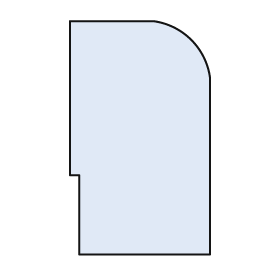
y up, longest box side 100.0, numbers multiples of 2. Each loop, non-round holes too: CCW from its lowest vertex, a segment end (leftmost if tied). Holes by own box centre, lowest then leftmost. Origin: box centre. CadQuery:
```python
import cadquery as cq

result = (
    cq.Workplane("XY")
    .moveTo(-26.0, -50.0)
    .lineTo(30.0, -50.0)
    .lineTo(30.0, 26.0)
    .threePointArc((22.0, 42.0), (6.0, 50.0))
    .lineTo(-30.0, 50.0)
    .lineTo(-30.0, -16.0)
    .lineTo(-26.0, -16.0)
    .close()
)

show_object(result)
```